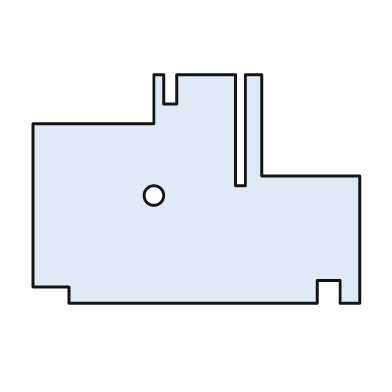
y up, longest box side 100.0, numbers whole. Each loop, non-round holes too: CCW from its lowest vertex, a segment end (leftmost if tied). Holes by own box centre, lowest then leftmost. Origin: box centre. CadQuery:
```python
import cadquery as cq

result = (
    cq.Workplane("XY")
    .moveTo(-39.0, -35.0)
    .lineTo(37.0, -35.0)
    .lineTo(37.0, -28.0)
    .lineTo(44.0, -28.0)
    .lineTo(44.0, -35.0)
    .lineTo(50.0, -35.0)
    .lineTo(50.0, 4.0)
    .lineTo(20.0, 4.0)
    .lineTo(20.0, 35.0)
    .lineTo(15.0, 35.0)
    .lineTo(15.0, 1.0)
    .lineTo(12.0, 1.0)
    .lineTo(12.0, 35.0)
    .lineTo(-6.0, 35.0)
    .lineTo(-6.0, 26.0)
    .lineTo(-10.0, 26.0)
    .lineTo(-10.0, 35.0)
    .lineTo(-13.0, 35.0)
    .lineTo(-13.0, 20.0)
    .lineTo(-50.0, 20.0)
    .lineTo(-50.0, -30.0)
    .lineTo(-39.0, -30.0)
    .close()
    .moveTo(-13.0, -2.0)
    .circle(3.0)
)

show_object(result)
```